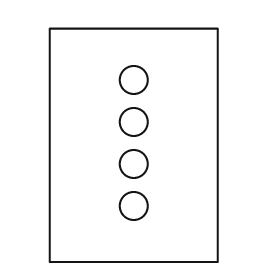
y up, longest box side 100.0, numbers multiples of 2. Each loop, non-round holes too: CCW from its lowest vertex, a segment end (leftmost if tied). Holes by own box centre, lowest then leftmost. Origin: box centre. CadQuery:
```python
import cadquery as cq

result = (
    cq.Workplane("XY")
    .moveTo(-36.0, -50.0)
    .lineTo(36.0, -50.0)
    .lineTo(36.0, 50.0)
    .lineTo(-36.0, 50.0)
    .close()
    .moveTo(0.0, -26.0)
    .circle(6.0)
    .moveTo(0.0, -8.0)
    .circle(6.0)
    .moveTo(0.0, 10.0)
    .circle(6.0)
    .moveTo(0.0, 28.0)
    .circle(6.0)
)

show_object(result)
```